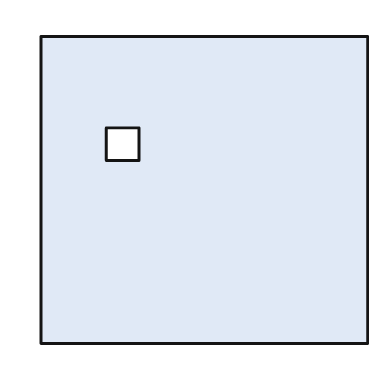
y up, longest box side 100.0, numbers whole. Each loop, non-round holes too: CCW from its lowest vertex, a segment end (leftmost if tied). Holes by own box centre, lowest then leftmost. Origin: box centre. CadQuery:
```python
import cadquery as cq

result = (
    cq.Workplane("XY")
    .moveTo(-50.0, -47.0)
    .lineTo(50.0, -47.0)
    .lineTo(50.0, 47.0)
    .lineTo(-50.0, 47.0)
    .close()
    .moveTo(-30.0, 9.0)
    .lineTo(-20.0, 9.0)
    .lineTo(-20.0, 19.0)
    .lineTo(-30.0, 19.0)
    .close()
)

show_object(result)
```